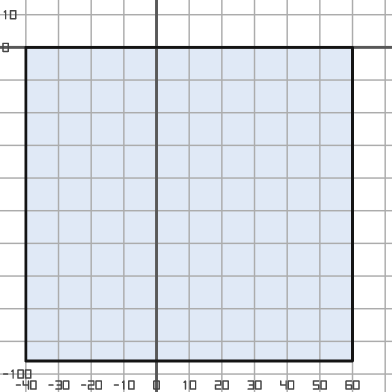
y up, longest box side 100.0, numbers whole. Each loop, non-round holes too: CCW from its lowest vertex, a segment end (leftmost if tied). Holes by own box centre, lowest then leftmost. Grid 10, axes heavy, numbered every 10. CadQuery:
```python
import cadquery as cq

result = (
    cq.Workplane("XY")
    .moveTo(-40.0, -96.0)
    .lineTo(60.0, -96.0)
    .lineTo(60.0, 0.0)
    .lineTo(-40.0, 0.0)
    .close()
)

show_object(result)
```